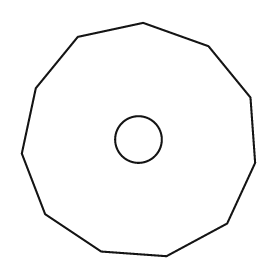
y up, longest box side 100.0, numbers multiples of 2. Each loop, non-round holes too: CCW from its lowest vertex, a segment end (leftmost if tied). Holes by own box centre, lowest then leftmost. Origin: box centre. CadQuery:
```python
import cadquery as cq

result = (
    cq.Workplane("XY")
    .moveTo(12.0, -50.0)
    .lineTo(38.0, -36.0)
    .lineTo(50.0, -10.0)
    .lineTo(48.0, 18.0)
    .lineTo(30.0, 40.0)
    .lineTo(2.0, 50.0)
    .lineTo(-26.0, 44.0)
    .lineTo(-44.0, 22.0)
    .lineTo(-50.0, -6.0)
    .lineTo(-40.0, -32.0)
    .lineTo(-16.0, -48.0)
    .close()
    .moveTo(0.0, 0.0)
    .circle(10.0)
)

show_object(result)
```